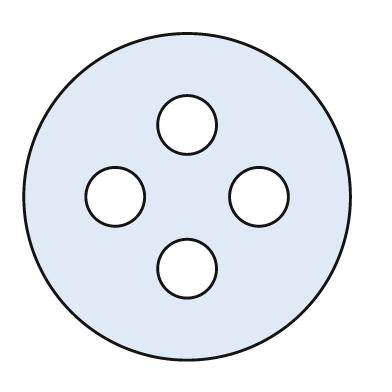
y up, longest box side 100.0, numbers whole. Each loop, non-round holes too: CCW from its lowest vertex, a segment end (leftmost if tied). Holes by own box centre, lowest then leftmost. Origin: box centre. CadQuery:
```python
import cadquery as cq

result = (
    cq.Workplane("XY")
    .moveTo(0.0, 0.0)
    .circle(50.0)
    .moveTo(0.0, -22.0)
    .circle(9.0)
    .moveTo(-22.0, 0.0)
    .circle(9.0)
    .moveTo(22.0, 0.0)
    .circle(9.0)
    .moveTo(0.0, 22.0)
    .circle(9.0)
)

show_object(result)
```